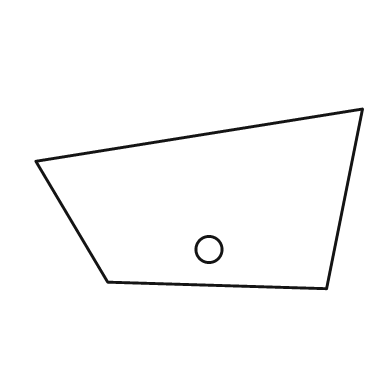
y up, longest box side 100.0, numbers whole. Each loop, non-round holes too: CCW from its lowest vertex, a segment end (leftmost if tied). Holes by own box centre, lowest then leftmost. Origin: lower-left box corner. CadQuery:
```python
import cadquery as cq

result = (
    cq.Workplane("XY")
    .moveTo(89.0, 0.0)
    .lineTo(100.0, 55.0)
    .lineTo(0.0, 39.0)
    .lineTo(22.0, 2.0)
    .close()
    .moveTo(53.0, 12.0)
    .circle(4.0)
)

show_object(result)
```